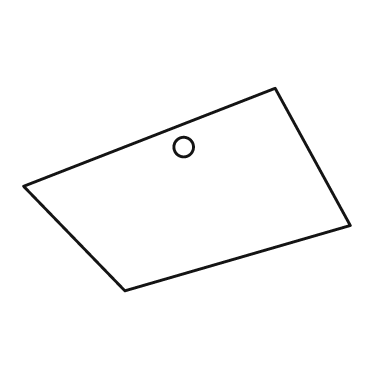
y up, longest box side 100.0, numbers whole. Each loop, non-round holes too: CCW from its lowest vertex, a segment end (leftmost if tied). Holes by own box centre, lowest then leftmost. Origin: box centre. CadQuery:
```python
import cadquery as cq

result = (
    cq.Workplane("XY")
    .moveTo(-19.0, -31.0)
    .lineTo(50.0, -11.0)
    .lineTo(27.0, 31.0)
    .lineTo(-50.0, 1.0)
    .close()
    .moveTo(-1.0, 13.0)
    .circle(3.0)
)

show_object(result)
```